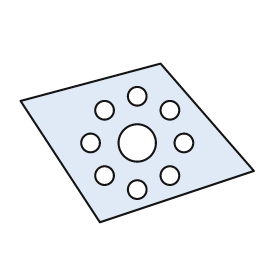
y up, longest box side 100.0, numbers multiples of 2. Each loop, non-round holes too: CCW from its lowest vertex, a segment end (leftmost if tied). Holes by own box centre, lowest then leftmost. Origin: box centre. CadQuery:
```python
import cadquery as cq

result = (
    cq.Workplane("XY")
    .moveTo(-16.0, -34.0)
    .lineTo(50.0, -12.0)
    .lineTo(10.0, 34.0)
    .lineTo(-50.0, 18.0)
    .close()
    .moveTo(0.0, -20.0)
    .circle(4.0)
    .moveTo(-14.0, -14.0)
    .circle(4.0)
    .moveTo(14.0, -14.0)
    .circle(4.0)
    .moveTo(-20.0, 0.0)
    .circle(4.0)
    .moveTo(0.0, 0.0)
    .circle(8.0)
    .moveTo(20.0, 0.0)
    .circle(4.0)
    .moveTo(-14.0, 14.0)
    .circle(4.0)
    .moveTo(14.0, 14.0)
    .circle(4.0)
    .moveTo(0.0, 20.0)
    .circle(4.0)
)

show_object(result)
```